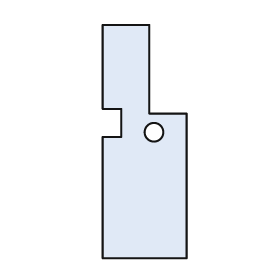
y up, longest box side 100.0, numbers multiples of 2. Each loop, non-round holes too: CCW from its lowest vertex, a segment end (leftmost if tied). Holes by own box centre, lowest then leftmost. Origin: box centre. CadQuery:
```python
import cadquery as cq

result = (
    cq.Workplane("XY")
    .moveTo(-18.0, -50.0)
    .lineTo(18.0, -50.0)
    .lineTo(18.0, 12.0)
    .lineTo(2.0, 12.0)
    .lineTo(2.0, 50.0)
    .lineTo(-18.0, 50.0)
    .lineTo(-18.0, 14.0)
    .lineTo(-10.0, 14.0)
    .lineTo(-10.0, 2.0)
    .lineTo(-18.0, 2.0)
    .close()
    .moveTo(4.0, 4.0)
    .circle(4.0)
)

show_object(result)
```